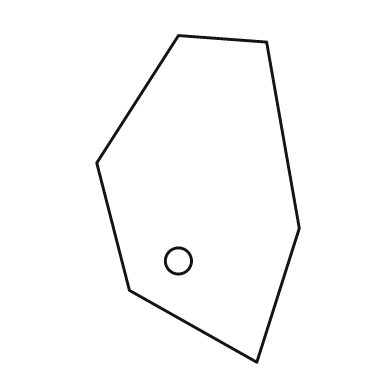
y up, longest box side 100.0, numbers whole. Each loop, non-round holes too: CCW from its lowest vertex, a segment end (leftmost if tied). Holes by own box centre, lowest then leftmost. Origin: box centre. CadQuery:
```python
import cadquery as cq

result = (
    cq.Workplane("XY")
    .moveTo(18.0, -50.0)
    .lineTo(31.0, -9.0)
    .lineTo(21.0, 48.0)
    .lineTo(-6.0, 50.0)
    .lineTo(-31.0, 11.0)
    .lineTo(-21.0, -28.0)
    .close()
    .moveTo(-6.0, -19.0)
    .circle(4.0)
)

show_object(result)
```